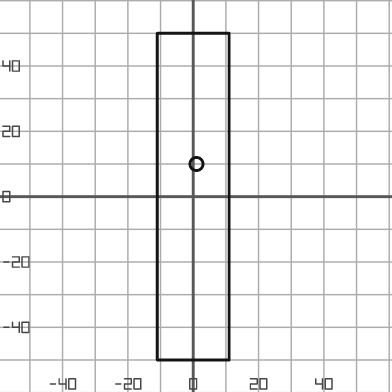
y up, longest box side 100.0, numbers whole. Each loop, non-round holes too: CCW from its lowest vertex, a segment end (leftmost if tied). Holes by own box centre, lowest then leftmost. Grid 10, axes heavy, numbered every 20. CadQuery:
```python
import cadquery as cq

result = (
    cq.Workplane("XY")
    .moveTo(-11.0, -50.0)
    .lineTo(11.0, -50.0)
    .lineTo(11.0, 50.0)
    .lineTo(-11.0, 50.0)
    .close()
    .moveTo(1.0, 10.0)
    .circle(2.0)
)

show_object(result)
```